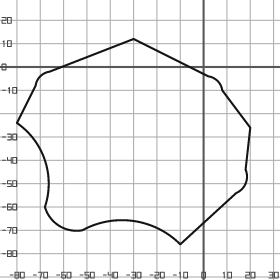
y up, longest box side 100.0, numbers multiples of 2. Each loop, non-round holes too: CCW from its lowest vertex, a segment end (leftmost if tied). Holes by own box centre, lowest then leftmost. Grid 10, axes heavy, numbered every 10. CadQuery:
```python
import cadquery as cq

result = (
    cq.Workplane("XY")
    .moveTo(-10.0, -76.0)
    .lineTo(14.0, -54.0)
    .threePointArc((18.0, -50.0), (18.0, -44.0))
    .lineTo(20.0, -26.0)
    .lineTo(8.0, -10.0)
    .threePointArc((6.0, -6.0), (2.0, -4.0))
    .lineTo(-30.0, 12.0)
    .lineTo(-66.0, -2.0)
    .threePointArc((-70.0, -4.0), (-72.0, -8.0))
    .lineTo(-80.0, -24.0)
    .threePointArc((-68.0, -40.0), (-68.0, -60.0))
    .threePointArc((-62.0, -68.0), (-52.0, -70.0))
    .threePointArc((-30.0, -66.0), (-10.0, -76.0))
    .close()
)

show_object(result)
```